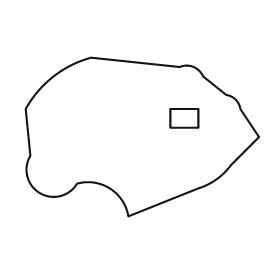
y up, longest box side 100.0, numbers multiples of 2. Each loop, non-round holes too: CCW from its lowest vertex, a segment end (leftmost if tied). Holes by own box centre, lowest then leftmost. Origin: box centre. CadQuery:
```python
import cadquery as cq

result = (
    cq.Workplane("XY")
    .moveTo(-6.0, -34.0)
    .lineTo(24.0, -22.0)
    .threePointArc((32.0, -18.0), (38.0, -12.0))
    .lineTo(50.0, 0.0)
    .lineTo(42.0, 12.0)
    .threePointArc((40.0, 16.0), (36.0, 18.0))
    .lineTo(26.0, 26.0)
    .threePointArc((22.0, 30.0), (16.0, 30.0))
    .lineTo(-22.0, 34.0)
    .threePointArc((-38.0, 26.0), (-50.0, 12.0))
    .lineTo(-48.0, -8.0)
    .threePointArc((-44.0, -24.0), (-28.0, -20.0))
    .threePointArc((-14.0, -22.0), (-6.0, -34.0))
    .close()
    .moveTo(12.0, 4.0)
    .lineTo(24.0, 4.0)
    .lineTo(24.0, 12.0)
    .lineTo(12.0, 12.0)
    .close()
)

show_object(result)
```